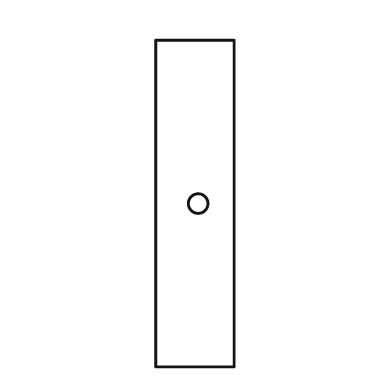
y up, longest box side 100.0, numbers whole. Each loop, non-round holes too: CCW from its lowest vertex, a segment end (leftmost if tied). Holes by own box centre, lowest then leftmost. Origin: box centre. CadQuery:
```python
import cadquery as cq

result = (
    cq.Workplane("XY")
    .moveTo(-12.0, -50.0)
    .lineTo(12.0, -50.0)
    .lineTo(12.0, 50.0)
    .lineTo(-12.0, 50.0)
    .close()
    .moveTo(1.0, 0.0)
    .circle(3.0)
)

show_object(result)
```